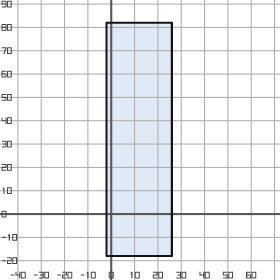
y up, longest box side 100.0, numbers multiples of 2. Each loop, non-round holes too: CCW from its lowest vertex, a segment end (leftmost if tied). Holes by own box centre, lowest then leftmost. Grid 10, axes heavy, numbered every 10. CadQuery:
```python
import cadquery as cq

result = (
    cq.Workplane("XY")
    .moveTo(-2.0, -18.0)
    .lineTo(26.0, -18.0)
    .lineTo(26.0, 82.0)
    .lineTo(-2.0, 82.0)
    .close()
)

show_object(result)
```